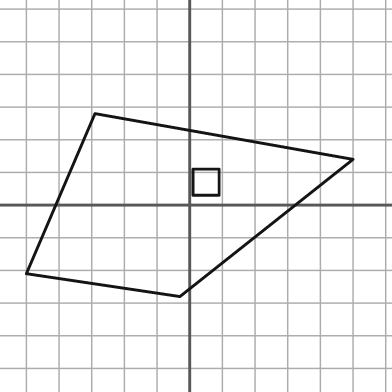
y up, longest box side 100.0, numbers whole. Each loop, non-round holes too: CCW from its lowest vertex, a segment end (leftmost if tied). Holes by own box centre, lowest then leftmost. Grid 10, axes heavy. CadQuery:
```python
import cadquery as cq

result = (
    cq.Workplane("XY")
    .moveTo(-3.0, -28.0)
    .lineTo(50.0, 14.0)
    .lineTo(-29.0, 28.0)
    .lineTo(-50.0, -21.0)
    .close()
    .moveTo(1.0, 3.0)
    .lineTo(9.0, 3.0)
    .lineTo(9.0, 11.0)
    .lineTo(1.0, 11.0)
    .close()
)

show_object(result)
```